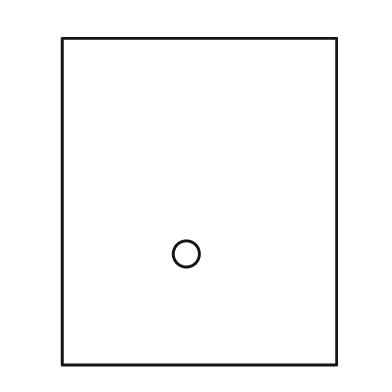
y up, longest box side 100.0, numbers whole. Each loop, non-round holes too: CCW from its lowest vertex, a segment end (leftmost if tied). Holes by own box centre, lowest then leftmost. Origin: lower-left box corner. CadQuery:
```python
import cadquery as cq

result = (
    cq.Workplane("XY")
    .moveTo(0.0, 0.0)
    .lineTo(84.0, 0.0)
    .lineTo(84.0, 100.0)
    .lineTo(0.0, 100.0)
    .close()
    .moveTo(38.0, 34.0)
    .circle(4.0)
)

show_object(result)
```